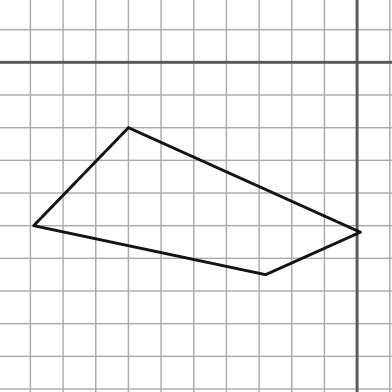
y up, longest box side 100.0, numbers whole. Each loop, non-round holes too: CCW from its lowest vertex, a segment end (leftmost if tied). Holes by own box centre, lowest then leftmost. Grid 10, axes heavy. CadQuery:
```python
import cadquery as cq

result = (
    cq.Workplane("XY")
    .moveTo(-28.0, -65.0)
    .lineTo(1.0, -52.0)
    .lineTo(-70.0, -20.0)
    .lineTo(-99.0, -50.0)
    .close()
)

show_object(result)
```